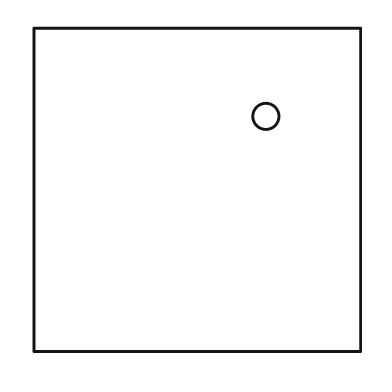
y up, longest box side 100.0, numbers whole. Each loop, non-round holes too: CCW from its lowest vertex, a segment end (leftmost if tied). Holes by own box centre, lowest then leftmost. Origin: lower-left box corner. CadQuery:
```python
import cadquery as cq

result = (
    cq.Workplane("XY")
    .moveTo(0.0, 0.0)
    .lineTo(100.0, 0.0)
    .lineTo(100.0, 99.0)
    .lineTo(0.0, 99.0)
    .close()
    .moveTo(71.0, 72.0)
    .circle(4.0)
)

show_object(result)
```